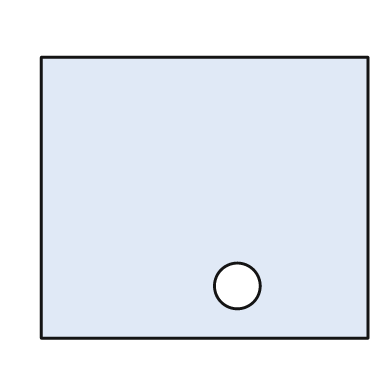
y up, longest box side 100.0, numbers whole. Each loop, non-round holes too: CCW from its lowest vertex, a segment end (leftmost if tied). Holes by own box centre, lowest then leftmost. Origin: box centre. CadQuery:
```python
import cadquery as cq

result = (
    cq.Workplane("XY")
    .moveTo(-50.0, -43.0)
    .lineTo(50.0, -43.0)
    .lineTo(50.0, 43.0)
    .lineTo(-50.0, 43.0)
    .close()
    .moveTo(10.0, -27.0)
    .circle(7.0)
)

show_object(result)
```